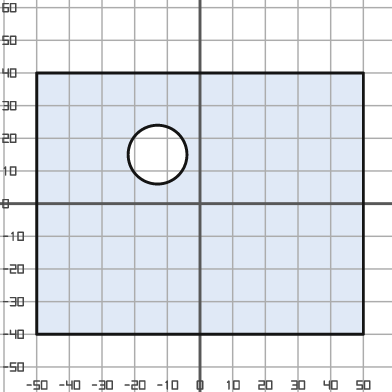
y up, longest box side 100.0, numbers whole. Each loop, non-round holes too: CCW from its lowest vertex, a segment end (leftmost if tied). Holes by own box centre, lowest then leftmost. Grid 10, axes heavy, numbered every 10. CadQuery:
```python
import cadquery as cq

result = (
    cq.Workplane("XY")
    .moveTo(-50.0, -40.0)
    .lineTo(50.0, -40.0)
    .lineTo(50.0, 40.0)
    .lineTo(-50.0, 40.0)
    .close()
    .moveTo(-13.0, 15.0)
    .circle(9.0)
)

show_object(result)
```